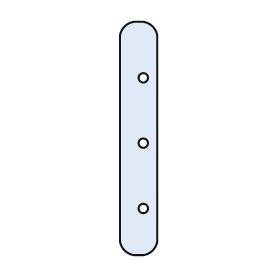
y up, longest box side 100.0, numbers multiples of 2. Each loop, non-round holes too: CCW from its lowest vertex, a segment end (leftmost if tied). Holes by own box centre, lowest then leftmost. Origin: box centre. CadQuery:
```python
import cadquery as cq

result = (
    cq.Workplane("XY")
    .moveTo(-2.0, -50.0)
    .lineTo(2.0, -50.0)
    .threePointArc((6.0, -48.0), (8.0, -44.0))
    .lineTo(8.0, 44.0)
    .threePointArc((6.0, 48.0), (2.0, 50.0))
    .lineTo(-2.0, 50.0)
    .threePointArc((-6.0, 48.0), (-8.0, 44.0))
    .lineTo(-8.0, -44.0)
    .threePointArc((-6.0, -48.0), (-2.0, -50.0))
    .close()
    .moveTo(2.0, -30.0)
    .circle(2.0)
    .moveTo(2.0, -2.0)
    .circle(2.0)
    .moveTo(2.0, 26.0)
    .circle(2.0)
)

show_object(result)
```